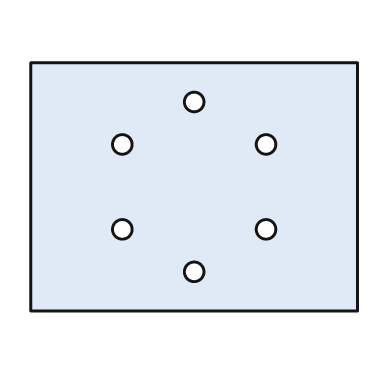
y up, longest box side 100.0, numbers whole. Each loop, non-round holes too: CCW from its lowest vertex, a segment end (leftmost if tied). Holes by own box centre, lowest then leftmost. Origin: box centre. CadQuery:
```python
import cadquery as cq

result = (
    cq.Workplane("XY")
    .moveTo(-50.0, -38.0)
    .lineTo(50.0, -38.0)
    .lineTo(50.0, 38.0)
    .lineTo(-50.0, 38.0)
    .close()
    .moveTo(0.0, -26.0)
    .circle(3.0)
    .moveTo(-22.0, -13.0)
    .circle(3.0)
    .moveTo(22.0, -13.0)
    .circle(3.0)
    .moveTo(-22.0, 13.0)
    .circle(3.0)
    .moveTo(22.0, 13.0)
    .circle(3.0)
    .moveTo(0.0, 26.0)
    .circle(3.0)
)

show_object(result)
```